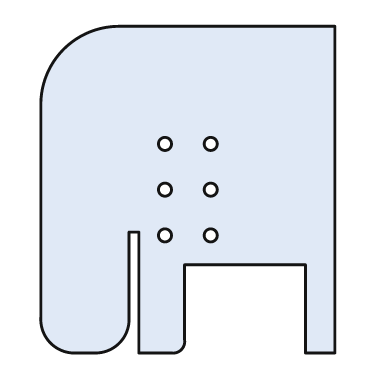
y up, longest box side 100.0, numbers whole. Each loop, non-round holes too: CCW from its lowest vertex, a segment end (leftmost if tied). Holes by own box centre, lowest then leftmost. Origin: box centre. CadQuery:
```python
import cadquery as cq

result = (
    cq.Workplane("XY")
    .moveTo(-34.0, -50.0)
    .lineTo(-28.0, -50.0)
    .threePointArc((-21.0, -47.0), (-18.0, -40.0))
    .lineTo(-18.0, -13.0)
    .lineTo(-15.0, -13.0)
    .lineTo(-15.0, -50.0)
    .lineTo(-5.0, -50.0)
    .threePointArc((-2.0, -49.0), (-1.0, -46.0))
    .lineTo(-1.0, -23.0)
    .lineTo(36.0, -23.0)
    .lineTo(36.0, -50.0)
    .lineTo(45.0, -50.0)
    .lineTo(45.0, 50.0)
    .lineTo(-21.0, 50.0)
    .threePointArc((-38.0, 43.0), (-45.0, 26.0))
    .lineTo(-45.0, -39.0)
    .threePointArc((-42.0, -47.0), (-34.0, -50.0))
    .close()
    .moveTo(-7.0, -14.0)
    .circle(2.0)
    .moveTo(7.0, -14.0)
    .circle(2.0)
    .moveTo(-7.0, 0.0)
    .circle(2.0)
    .moveTo(7.0, 0.0)
    .circle(2.0)
    .moveTo(-7.0, 14.0)
    .circle(2.0)
    .moveTo(7.0, 14.0)
    .circle(2.0)
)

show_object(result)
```